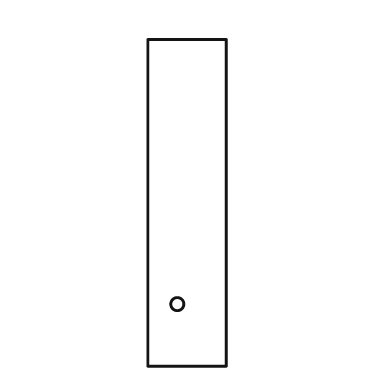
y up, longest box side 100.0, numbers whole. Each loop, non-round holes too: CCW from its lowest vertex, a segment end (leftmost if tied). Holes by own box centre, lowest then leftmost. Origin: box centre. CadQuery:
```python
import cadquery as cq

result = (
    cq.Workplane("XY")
    .moveTo(-12.0, -50.0)
    .lineTo(12.0, -50.0)
    .lineTo(12.0, 50.0)
    .lineTo(-12.0, 50.0)
    .close()
    .moveTo(-3.0, -31.0)
    .circle(2.0)
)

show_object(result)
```